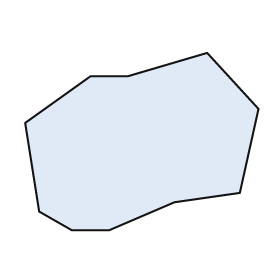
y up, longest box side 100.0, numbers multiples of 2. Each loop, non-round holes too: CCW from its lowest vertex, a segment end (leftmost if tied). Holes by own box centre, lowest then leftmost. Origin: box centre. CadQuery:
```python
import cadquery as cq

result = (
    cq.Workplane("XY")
    .moveTo(-30.0, -38.0)
    .lineTo(-14.0, -38.0)
    .lineTo(14.0, -26.0)
    .lineTo(42.0, -22.0)
    .lineTo(50.0, 14.0)
    .lineTo(28.0, 38.0)
    .lineTo(-6.0, 28.0)
    .lineTo(-22.0, 28.0)
    .lineTo(-50.0, 8.0)
    .lineTo(-44.0, -30.0)
    .close()
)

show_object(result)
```